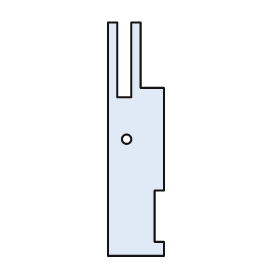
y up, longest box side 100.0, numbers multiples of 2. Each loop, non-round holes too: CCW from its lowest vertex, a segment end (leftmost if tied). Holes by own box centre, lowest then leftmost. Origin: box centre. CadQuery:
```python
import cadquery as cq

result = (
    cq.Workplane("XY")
    .moveTo(-12.0, -50.0)
    .lineTo(12.0, -50.0)
    .lineTo(12.0, -44.0)
    .lineTo(8.0, -44.0)
    .lineTo(8.0, -22.0)
    .lineTo(12.0, -22.0)
    .lineTo(12.0, 22.0)
    .lineTo(2.0, 22.0)
    .lineTo(2.0, 50.0)
    .lineTo(-2.0, 50.0)
    .lineTo(-2.0, 18.0)
    .lineTo(-8.0, 18.0)
    .lineTo(-8.0, 50.0)
    .lineTo(-12.0, 50.0)
    .close()
    .moveTo(-4.0, 0.0)
    .circle(2.0)
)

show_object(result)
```